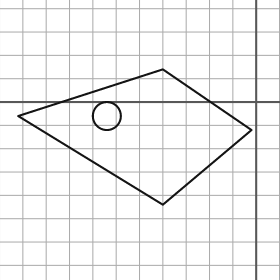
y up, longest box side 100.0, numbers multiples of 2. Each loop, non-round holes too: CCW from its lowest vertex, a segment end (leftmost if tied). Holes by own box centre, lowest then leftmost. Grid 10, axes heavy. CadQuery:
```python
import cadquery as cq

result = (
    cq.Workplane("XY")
    .moveTo(-40.0, -44.0)
    .lineTo(-2.0, -12.0)
    .lineTo(-40.0, 14.0)
    .lineTo(-102.0, -6.0)
    .close()
    .moveTo(-64.0, -6.0)
    .circle(6.0)
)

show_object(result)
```